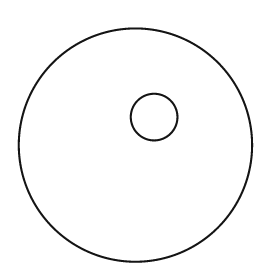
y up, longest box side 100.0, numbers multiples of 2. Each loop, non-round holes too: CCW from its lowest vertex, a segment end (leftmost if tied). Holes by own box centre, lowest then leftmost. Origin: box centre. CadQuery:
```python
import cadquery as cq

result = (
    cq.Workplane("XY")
    .moveTo(0.0, 0.0)
    .circle(50.0)
    .moveTo(8.0, 12.0)
    .circle(10.0)
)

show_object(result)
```